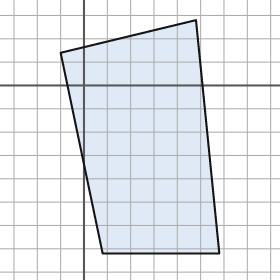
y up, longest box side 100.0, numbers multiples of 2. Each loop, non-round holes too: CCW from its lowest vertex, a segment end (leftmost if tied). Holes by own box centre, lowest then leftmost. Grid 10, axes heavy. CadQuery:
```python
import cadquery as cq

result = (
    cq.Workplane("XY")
    .moveTo(8.0, -72.0)
    .lineTo(58.0, -72.0)
    .lineTo(48.0, 28.0)
    .lineTo(-10.0, 14.0)
    .close()
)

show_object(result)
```